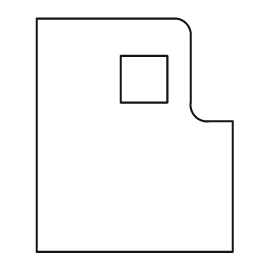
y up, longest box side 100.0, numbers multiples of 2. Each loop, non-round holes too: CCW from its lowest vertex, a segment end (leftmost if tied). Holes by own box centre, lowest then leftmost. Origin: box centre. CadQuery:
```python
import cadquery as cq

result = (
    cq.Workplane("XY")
    .moveTo(-42.0, -50.0)
    .lineTo(42.0, -50.0)
    .lineTo(42.0, 6.0)
    .lineTo(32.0, 6.0)
    .threePointArc((26.0, 8.0), (24.0, 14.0))
    .lineTo(24.0, 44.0)
    .threePointArc((22.0, 48.0), (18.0, 50.0))
    .lineTo(-42.0, 50.0)
    .close()
    .moveTo(-6.0, 14.0)
    .lineTo(14.0, 14.0)
    .lineTo(14.0, 34.0)
    .lineTo(-6.0, 34.0)
    .close()
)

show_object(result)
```